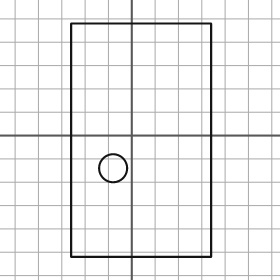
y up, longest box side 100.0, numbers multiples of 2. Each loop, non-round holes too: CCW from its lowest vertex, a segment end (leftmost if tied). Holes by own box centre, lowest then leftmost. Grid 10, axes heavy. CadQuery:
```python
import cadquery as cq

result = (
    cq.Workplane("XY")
    .moveTo(-26.0, -52.0)
    .lineTo(34.0, -52.0)
    .lineTo(34.0, 48.0)
    .lineTo(-26.0, 48.0)
    .close()
    .moveTo(-8.0, -14.0)
    .circle(6.0)
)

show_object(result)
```